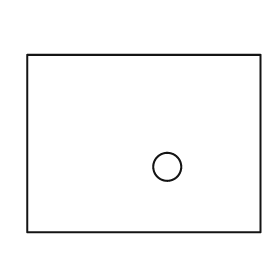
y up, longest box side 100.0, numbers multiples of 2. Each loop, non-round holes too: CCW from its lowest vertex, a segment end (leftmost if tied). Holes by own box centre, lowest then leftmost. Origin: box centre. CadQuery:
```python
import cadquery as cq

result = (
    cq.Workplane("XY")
    .moveTo(-50.0, -38.0)
    .lineTo(50.0, -38.0)
    .lineTo(50.0, 38.0)
    .lineTo(-50.0, 38.0)
    .close()
    .moveTo(10.0, -10.0)
    .circle(6.0)
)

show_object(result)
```